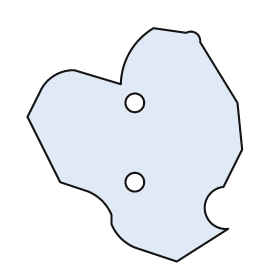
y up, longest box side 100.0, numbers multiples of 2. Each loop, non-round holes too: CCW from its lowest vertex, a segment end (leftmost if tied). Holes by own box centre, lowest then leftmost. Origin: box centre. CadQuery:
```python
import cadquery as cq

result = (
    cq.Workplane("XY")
    .moveTo(18.0, -50.0)
    .lineTo(40.0, -36.0)
    .threePointArc((30.0, -28.0), (38.0, -18.0))
    .lineTo(46.0, -2.0)
    .lineTo(44.0, 18.0)
    .lineTo(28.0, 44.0)
    .threePointArc((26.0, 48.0), (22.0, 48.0))
    .lineTo(8.0, 50.0)
    .threePointArc((-2.0, 40.0), (-6.0, 26.0))
    .lineTo(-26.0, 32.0)
    .threePointArc((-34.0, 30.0), (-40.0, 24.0))
    .lineTo(-46.0, 12.0)
    .lineTo(-32.0, -16.0)
    .lineTo(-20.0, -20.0)
    .threePointArc((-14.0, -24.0), (-10.0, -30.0))
    .lineTo(-10.0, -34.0)
    .threePointArc((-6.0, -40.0), (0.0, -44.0))
    .close()
    .moveTo(0.0, -16.0)
    .circle(4.0)
    .moveTo(0.0, 18.0)
    .circle(4.0)
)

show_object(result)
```